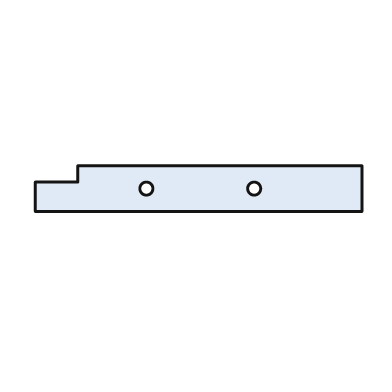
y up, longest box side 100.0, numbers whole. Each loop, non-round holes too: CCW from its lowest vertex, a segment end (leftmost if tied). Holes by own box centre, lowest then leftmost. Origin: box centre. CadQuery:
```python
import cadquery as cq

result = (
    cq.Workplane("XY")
    .moveTo(-50.0, -7.0)
    .lineTo(50.0, -7.0)
    .lineTo(50.0, 7.0)
    .lineTo(-37.0, 7.0)
    .lineTo(-37.0, 2.0)
    .lineTo(-50.0, 2.0)
    .close()
    .moveTo(-16.0, 0.0)
    .circle(2.0)
    .moveTo(17.0, 0.0)
    .circle(2.0)
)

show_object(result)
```